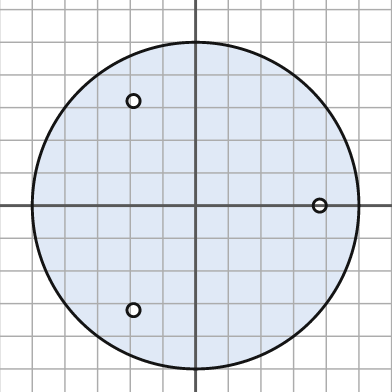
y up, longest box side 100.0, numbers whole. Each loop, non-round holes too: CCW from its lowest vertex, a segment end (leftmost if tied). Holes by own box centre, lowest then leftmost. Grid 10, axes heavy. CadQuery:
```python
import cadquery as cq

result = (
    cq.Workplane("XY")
    .moveTo(0.0, 0.0)
    .circle(50.0)
    .moveTo(-19.0, -32.0)
    .circle(2.0)
    .moveTo(38.0, 0.0)
    .circle(2.0)
    .moveTo(-19.0, 32.0)
    .circle(2.0)
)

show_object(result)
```